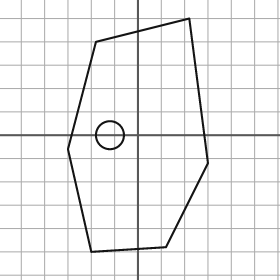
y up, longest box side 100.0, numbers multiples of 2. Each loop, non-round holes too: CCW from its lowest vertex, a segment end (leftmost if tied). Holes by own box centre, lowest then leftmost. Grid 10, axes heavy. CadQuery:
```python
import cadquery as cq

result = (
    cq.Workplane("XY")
    .moveTo(-20.0, -50.0)
    .lineTo(12.0, -48.0)
    .lineTo(30.0, -12.0)
    .lineTo(22.0, 50.0)
    .lineTo(-18.0, 40.0)
    .lineTo(-30.0, -6.0)
    .close()
    .moveTo(-12.0, 0.0)
    .circle(6.0)
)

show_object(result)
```